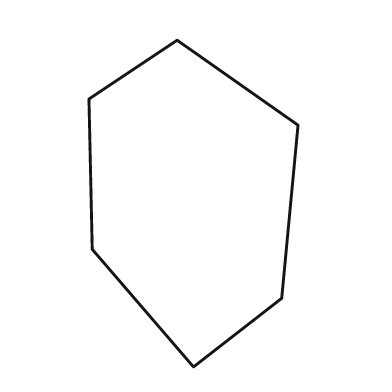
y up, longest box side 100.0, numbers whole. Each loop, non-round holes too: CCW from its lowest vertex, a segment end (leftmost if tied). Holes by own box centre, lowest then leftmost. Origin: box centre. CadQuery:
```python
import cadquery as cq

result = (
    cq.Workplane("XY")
    .moveTo(0.0, -50.0)
    .lineTo(27.0, -29.0)
    .lineTo(32.0, 24.0)
    .lineTo(-5.0, 50.0)
    .lineTo(-32.0, 32.0)
    .lineTo(-31.0, -14.0)
    .close()
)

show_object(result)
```